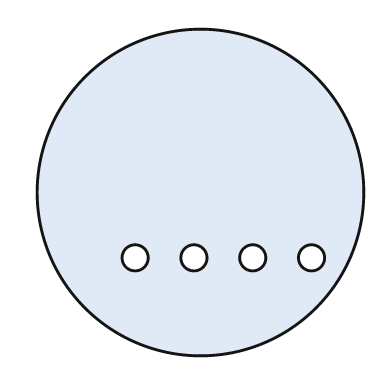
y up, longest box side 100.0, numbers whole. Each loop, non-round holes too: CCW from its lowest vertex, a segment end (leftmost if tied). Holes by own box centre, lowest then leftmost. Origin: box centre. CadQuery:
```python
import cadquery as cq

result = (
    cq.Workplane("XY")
    .moveTo(0.0, 0.0)
    .circle(50.0)
    .moveTo(-20.0, -20.0)
    .circle(4.0)
    .moveTo(-2.0, -20.0)
    .circle(4.0)
    .moveTo(16.0, -20.0)
    .circle(4.0)
    .moveTo(34.0, -20.0)
    .circle(4.0)
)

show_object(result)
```